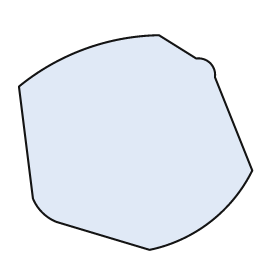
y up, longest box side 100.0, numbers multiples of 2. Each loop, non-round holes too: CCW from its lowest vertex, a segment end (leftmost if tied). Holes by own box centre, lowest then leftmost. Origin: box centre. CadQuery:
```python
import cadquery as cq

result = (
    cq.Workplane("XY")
    .moveTo(6.0, -46.0)
    .threePointArc((32.0, -34.0), (50.0, -12.0))
    .lineTo(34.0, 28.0)
    .threePointArc((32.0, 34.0), (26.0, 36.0))
    .lineTo(10.0, 46.0)
    .threePointArc((-22.0, 40.0), (-50.0, 24.0))
    .lineTo(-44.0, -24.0)
    .threePointArc((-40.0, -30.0), (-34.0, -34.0))
    .close()
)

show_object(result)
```